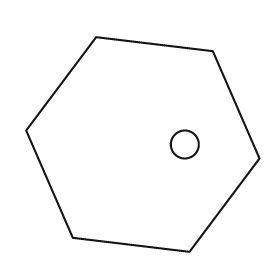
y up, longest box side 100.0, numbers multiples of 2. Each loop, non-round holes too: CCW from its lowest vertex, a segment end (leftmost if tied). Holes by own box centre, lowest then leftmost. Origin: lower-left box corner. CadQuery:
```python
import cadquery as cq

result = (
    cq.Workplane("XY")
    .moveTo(70.0, 0.0)
    .lineTo(100.0, 40.0)
    .lineTo(80.0, 86.0)
    .lineTo(30.0, 92.0)
    .lineTo(0.0, 52.0)
    .lineTo(20.0, 6.0)
    .close()
    .moveTo(68.0, 46.0)
    .circle(6.0)
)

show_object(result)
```